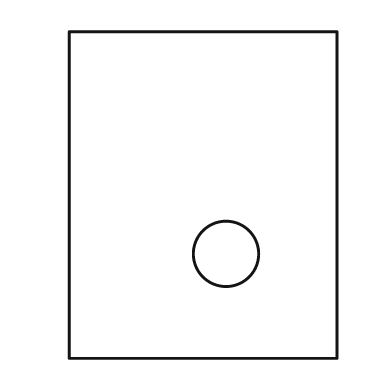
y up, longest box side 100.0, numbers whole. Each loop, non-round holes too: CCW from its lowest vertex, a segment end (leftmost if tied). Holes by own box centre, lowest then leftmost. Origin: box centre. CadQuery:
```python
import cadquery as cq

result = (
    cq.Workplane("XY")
    .moveTo(-41.0, -50.0)
    .lineTo(41.0, -50.0)
    .lineTo(41.0, 50.0)
    .lineTo(-41.0, 50.0)
    .close()
    .moveTo(7.0, -18.0)
    .circle(10.0)
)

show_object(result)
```